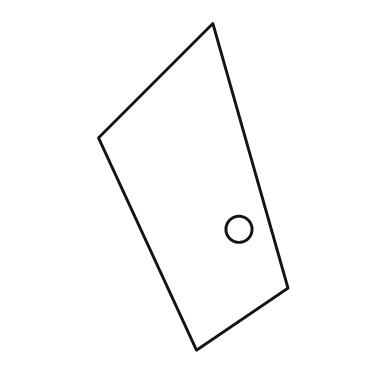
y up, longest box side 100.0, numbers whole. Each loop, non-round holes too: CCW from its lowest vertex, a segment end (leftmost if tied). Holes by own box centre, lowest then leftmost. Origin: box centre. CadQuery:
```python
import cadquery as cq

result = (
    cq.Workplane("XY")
    .moveTo(1.0, -50.0)
    .lineTo(29.0, -31.0)
    .lineTo(6.0, 50.0)
    .lineTo(-29.0, 15.0)
    .close()
    .moveTo(14.0, -13.0)
    .circle(4.0)
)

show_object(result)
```